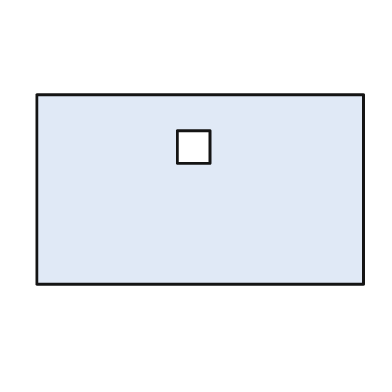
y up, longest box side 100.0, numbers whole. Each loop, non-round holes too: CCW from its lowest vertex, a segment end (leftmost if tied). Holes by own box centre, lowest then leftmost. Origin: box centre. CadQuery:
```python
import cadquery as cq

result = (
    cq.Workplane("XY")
    .moveTo(-50.0, -29.0)
    .lineTo(50.0, -29.0)
    .lineTo(50.0, 29.0)
    .lineTo(-50.0, 29.0)
    .close()
    .moveTo(-7.0, 8.0)
    .lineTo(3.0, 8.0)
    .lineTo(3.0, 18.0)
    .lineTo(-7.0, 18.0)
    .close()
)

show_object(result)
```